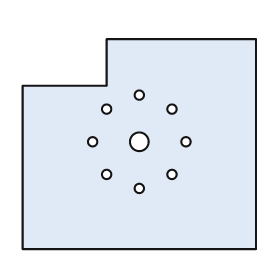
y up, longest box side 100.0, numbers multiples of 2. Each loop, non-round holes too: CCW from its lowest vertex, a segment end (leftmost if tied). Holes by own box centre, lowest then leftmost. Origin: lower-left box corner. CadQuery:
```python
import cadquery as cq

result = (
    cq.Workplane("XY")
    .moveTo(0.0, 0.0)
    .lineTo(100.0, 0.0)
    .lineTo(100.0, 90.0)
    .lineTo(36.0, 90.0)
    .lineTo(36.0, 70.0)
    .lineTo(0.0, 70.0)
    .close()
    .moveTo(50.0, 26.0)
    .circle(2.0)
    .moveTo(36.0, 32.0)
    .circle(2.0)
    .moveTo(64.0, 32.0)
    .circle(2.0)
    .moveTo(30.0, 46.0)
    .circle(2.0)
    .moveTo(50.0, 46.0)
    .circle(4.0)
    .moveTo(70.0, 46.0)
    .circle(2.0)
    .moveTo(36.0, 60.0)
    .circle(2.0)
    .moveTo(64.0, 60.0)
    .circle(2.0)
    .moveTo(50.0, 66.0)
    .circle(2.0)
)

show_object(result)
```